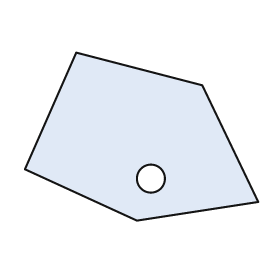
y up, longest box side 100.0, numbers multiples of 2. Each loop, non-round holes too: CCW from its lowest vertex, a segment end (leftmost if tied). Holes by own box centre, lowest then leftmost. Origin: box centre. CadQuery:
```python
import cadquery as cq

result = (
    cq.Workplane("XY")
    .moveTo(-2.0, -36.0)
    .lineTo(50.0, -28.0)
    .lineTo(26.0, 22.0)
    .lineTo(-28.0, 36.0)
    .lineTo(-50.0, -14.0)
    .close()
    .moveTo(4.0, -18.0)
    .circle(6.0)
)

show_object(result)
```